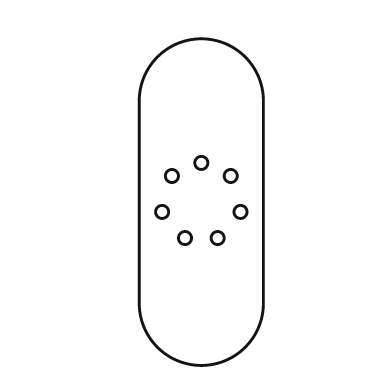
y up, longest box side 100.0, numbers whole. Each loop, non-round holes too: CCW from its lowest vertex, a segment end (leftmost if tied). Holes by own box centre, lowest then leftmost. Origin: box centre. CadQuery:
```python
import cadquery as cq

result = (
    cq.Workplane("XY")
    .moveTo(-19.0, -31.0)
    .threePointArc((0.0, -50.0), (19.0, -31.0))
    .lineTo(19.0, 31.0)
    .threePointArc((0.0, 50.0), (-19.0, 31.0))
    .close()
    .moveTo(-5.0, -11.0)
    .circle(2.0)
    .moveTo(5.0, -11.0)
    .circle(2.0)
    .moveTo(-12.0, -3.0)
    .circle(2.0)
    .moveTo(12.0, -3.0)
    .circle(2.0)
    .moveTo(-9.0, 8.0)
    .circle(2.0)
    .moveTo(9.0, 8.0)
    .circle(2.0)
    .moveTo(0.0, 12.0)
    .circle(2.0)
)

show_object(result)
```